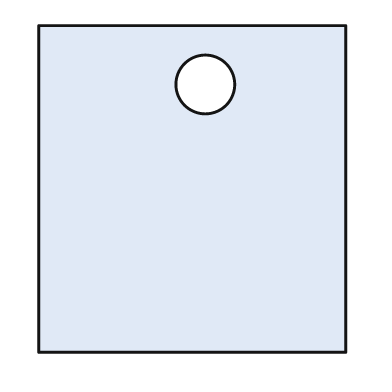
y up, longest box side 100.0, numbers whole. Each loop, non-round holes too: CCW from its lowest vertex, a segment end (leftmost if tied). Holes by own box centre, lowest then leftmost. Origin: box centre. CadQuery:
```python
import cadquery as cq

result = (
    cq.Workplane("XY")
    .moveTo(-47.0, -50.0)
    .lineTo(47.0, -50.0)
    .lineTo(47.0, 50.0)
    .lineTo(-47.0, 50.0)
    .close()
    .moveTo(4.0, 32.0)
    .circle(9.0)
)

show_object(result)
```